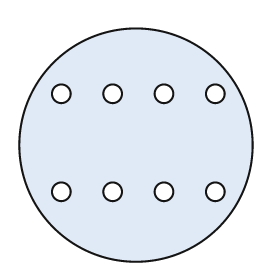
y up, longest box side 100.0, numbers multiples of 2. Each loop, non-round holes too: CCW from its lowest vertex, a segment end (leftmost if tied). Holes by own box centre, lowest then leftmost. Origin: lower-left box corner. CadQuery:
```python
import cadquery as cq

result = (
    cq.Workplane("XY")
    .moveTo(50.0, 50.0)
    .circle(50.0)
    .moveTo(18.0, 30.0)
    .circle(4.0)
    .moveTo(40.0, 30.0)
    .circle(4.0)
    .moveTo(62.0, 30.0)
    .circle(4.0)
    .moveTo(84.0, 30.0)
    .circle(4.0)
    .moveTo(18.0, 72.0)
    .circle(4.0)
    .moveTo(40.0, 72.0)
    .circle(4.0)
    .moveTo(62.0, 72.0)
    .circle(4.0)
    .moveTo(84.0, 72.0)
    .circle(4.0)
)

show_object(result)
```